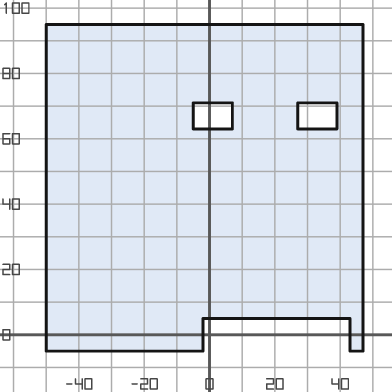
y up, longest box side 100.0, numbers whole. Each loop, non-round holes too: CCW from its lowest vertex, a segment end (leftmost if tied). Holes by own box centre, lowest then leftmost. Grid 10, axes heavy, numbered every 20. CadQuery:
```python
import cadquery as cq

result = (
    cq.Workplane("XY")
    .moveTo(-50.0, -5.0)
    .lineTo(-2.0, -5.0)
    .lineTo(-2.0, 5.0)
    .lineTo(43.0, 5.0)
    .lineTo(43.0, -5.0)
    .lineTo(47.0, -5.0)
    .lineTo(47.0, 95.0)
    .lineTo(-50.0, 95.0)
    .close()
    .moveTo(-5.0, 63.0)
    .lineTo(7.0, 63.0)
    .lineTo(7.0, 71.0)
    .lineTo(-5.0, 71.0)
    .close()
    .moveTo(27.0, 63.0)
    .lineTo(39.0, 63.0)
    .lineTo(39.0, 71.0)
    .lineTo(27.0, 71.0)
    .close()
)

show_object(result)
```